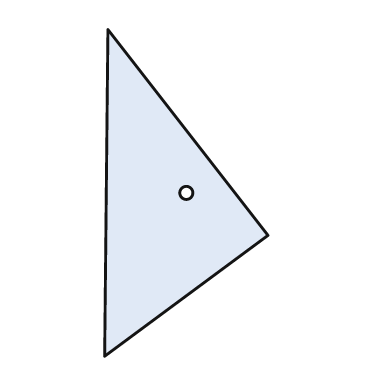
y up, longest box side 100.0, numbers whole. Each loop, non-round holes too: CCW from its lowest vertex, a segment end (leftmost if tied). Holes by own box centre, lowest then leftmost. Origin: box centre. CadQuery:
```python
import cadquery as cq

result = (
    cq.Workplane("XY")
    .moveTo(-25.0, -50.0)
    .lineTo(25.0, -13.0)
    .lineTo(-24.0, 50.0)
    .close()
    .moveTo(0.0, 0.0)
    .circle(2.0)
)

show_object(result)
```